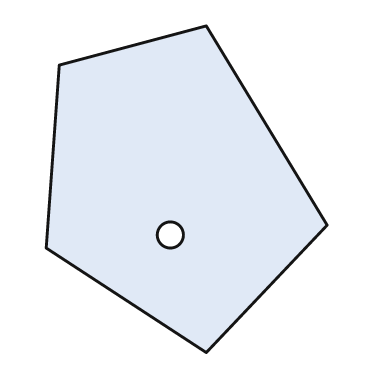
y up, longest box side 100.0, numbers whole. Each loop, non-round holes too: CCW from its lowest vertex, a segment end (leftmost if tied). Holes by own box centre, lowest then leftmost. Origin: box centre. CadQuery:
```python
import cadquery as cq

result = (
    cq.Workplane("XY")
    .moveTo(6.0, -50.0)
    .lineTo(43.0, -11.0)
    .lineTo(6.0, 50.0)
    .lineTo(-39.0, 38.0)
    .lineTo(-43.0, -18.0)
    .close()
    .moveTo(-5.0, -14.0)
    .circle(4.0)
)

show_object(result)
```